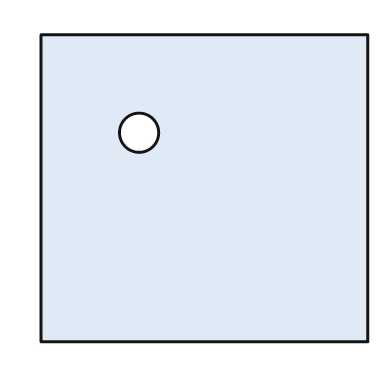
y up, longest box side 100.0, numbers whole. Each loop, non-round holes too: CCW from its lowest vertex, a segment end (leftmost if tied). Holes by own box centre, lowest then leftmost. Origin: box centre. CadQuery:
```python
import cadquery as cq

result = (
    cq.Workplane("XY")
    .moveTo(-50.0, -47.0)
    .lineTo(50.0, -47.0)
    .lineTo(50.0, 47.0)
    .lineTo(-50.0, 47.0)
    .close()
    .moveTo(-20.0, 17.0)
    .circle(6.0)
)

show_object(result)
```